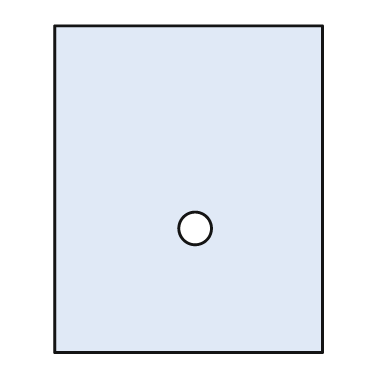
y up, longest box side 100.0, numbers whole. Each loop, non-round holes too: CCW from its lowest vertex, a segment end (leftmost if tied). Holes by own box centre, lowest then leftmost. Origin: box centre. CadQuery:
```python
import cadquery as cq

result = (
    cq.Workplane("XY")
    .moveTo(-41.0, -50.0)
    .lineTo(41.0, -50.0)
    .lineTo(41.0, 50.0)
    .lineTo(-41.0, 50.0)
    .close()
    .moveTo(2.0, -12.0)
    .circle(5.0)
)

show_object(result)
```